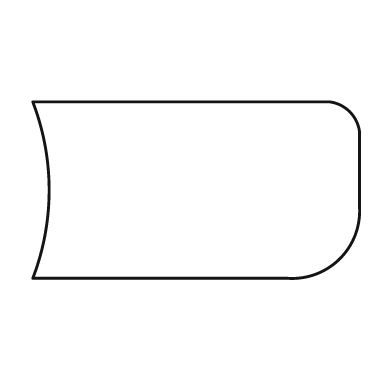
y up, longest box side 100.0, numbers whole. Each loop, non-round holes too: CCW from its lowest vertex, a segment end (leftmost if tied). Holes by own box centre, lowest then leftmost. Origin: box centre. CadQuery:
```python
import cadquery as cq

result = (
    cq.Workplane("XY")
    .moveTo(-50.0, -27.0)
    .lineTo(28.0, -27.0)
    .threePointArc((44.0, -21.0), (50.0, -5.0))
    .lineTo(50.0, 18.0)
    .threePointArc((47.0, 24.0), (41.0, 27.0))
    .lineTo(-50.0, 27.0)
    .threePointArc((-45.0, 0.0), (-50.0, -27.0))
    .close()
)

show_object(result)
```